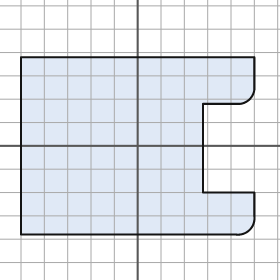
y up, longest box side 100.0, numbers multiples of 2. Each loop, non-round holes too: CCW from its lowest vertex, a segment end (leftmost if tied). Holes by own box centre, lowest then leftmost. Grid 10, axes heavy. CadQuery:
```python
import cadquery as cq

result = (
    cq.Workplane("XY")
    .moveTo(-50.0, -38.0)
    .lineTo(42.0, -38.0)
    .threePointArc((48.0, -36.0), (50.0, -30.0))
    .lineTo(50.0, -20.0)
    .lineTo(28.0, -20.0)
    .lineTo(28.0, 18.0)
    .lineTo(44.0, 18.0)
    .threePointArc((48.0, 20.0), (50.0, 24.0))
    .lineTo(50.0, 38.0)
    .lineTo(-50.0, 38.0)
    .close()
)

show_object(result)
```